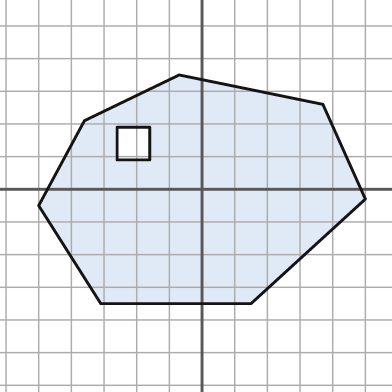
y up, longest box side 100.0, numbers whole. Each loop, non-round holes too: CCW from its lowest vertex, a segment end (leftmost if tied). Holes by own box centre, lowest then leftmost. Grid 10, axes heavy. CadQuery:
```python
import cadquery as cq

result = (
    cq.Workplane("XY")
    .moveTo(-31.0, -35.0)
    .lineTo(15.0, -35.0)
    .lineTo(50.0, -3.0)
    .lineTo(37.0, 26.0)
    .lineTo(-7.0, 35.0)
    .lineTo(-36.0, 21.0)
    .lineTo(-50.0, -5.0)
    .close()
    .moveTo(-26.0, 9.0)
    .lineTo(-16.0, 9.0)
    .lineTo(-16.0, 19.0)
    .lineTo(-26.0, 19.0)
    .close()
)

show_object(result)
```